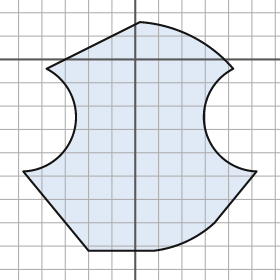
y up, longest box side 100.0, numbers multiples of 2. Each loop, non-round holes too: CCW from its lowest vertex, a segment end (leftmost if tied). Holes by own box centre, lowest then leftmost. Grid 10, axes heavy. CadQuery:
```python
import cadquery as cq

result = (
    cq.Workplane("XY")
    .moveTo(-20.0, -82.0)
    .lineTo(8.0, -82.0)
    .threePointArc((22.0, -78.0), (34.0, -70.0))
    .lineTo(52.0, -48.0)
    .threePointArc((30.0, -30.0), (42.0, -4.0))
    .threePointArc((24.0, 10.0), (2.0, 16.0))
    .lineTo(-38.0, -4.0)
    .threePointArc((-26.0, -30.0), (-48.0, -48.0))
    .close()
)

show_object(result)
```